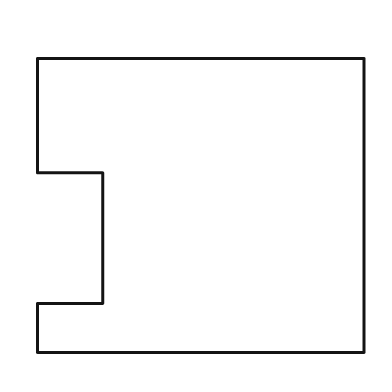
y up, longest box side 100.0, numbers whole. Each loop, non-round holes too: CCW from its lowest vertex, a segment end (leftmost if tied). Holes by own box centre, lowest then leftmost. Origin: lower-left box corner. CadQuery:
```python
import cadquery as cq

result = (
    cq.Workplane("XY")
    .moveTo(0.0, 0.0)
    .lineTo(100.0, 0.0)
    .lineTo(100.0, 90.0)
    .lineTo(0.0, 90.0)
    .lineTo(0.0, 55.0)
    .lineTo(20.0, 55.0)
    .lineTo(20.0, 15.0)
    .lineTo(0.0, 15.0)
    .close()
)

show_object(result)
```